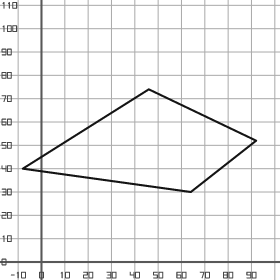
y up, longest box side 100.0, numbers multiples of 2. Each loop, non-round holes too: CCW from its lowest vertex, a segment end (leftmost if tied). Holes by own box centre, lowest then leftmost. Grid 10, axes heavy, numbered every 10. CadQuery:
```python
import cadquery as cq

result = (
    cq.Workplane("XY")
    .moveTo(64.0, 30.0)
    .lineTo(92.0, 52.0)
    .lineTo(46.0, 74.0)
    .lineTo(-8.0, 40.0)
    .close()
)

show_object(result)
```